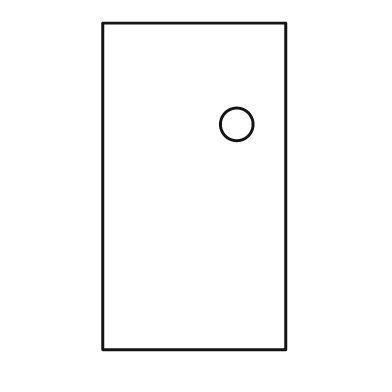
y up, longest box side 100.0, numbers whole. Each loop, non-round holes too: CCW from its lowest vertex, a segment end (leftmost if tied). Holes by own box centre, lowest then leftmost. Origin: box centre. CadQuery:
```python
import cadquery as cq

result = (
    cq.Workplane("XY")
    .moveTo(-28.0, -50.0)
    .lineTo(28.0, -50.0)
    .lineTo(28.0, 50.0)
    .lineTo(-28.0, 50.0)
    .close()
    .moveTo(13.0, 19.0)
    .circle(5.0)
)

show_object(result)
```